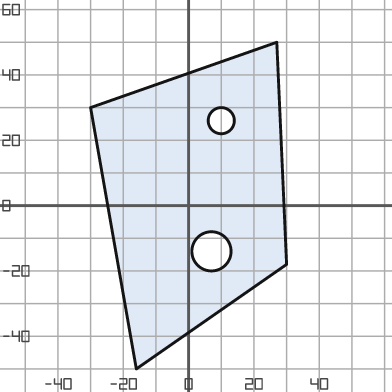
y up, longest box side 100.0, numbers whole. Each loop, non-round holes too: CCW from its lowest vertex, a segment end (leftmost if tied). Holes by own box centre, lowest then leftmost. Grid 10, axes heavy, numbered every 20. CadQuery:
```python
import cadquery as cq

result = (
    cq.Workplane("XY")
    .moveTo(-16.0, -50.0)
    .lineTo(30.0, -18.0)
    .lineTo(27.0, 50.0)
    .lineTo(-30.0, 30.0)
    .close()
    .moveTo(7.0, -14.0)
    .circle(6.0)
    .moveTo(10.0, 26.0)
    .circle(4.0)
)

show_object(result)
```